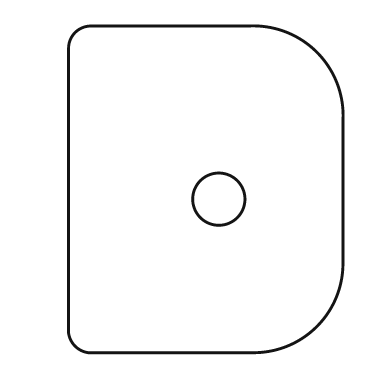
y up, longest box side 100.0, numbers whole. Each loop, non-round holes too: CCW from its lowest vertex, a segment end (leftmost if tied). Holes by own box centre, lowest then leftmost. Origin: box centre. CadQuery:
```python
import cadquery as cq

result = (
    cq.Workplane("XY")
    .moveTo(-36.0, -50.0)
    .lineTo(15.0, -50.0)
    .threePointArc((34.0, -42.0), (42.0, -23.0))
    .lineTo(42.0, 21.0)
    .threePointArc((34.0, 42.0), (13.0, 50.0))
    .lineTo(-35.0, 50.0)
    .threePointArc((-40.0, 48.0), (-42.0, 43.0))
    .lineTo(-42.0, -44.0)
    .threePointArc((-40.0, -48.0), (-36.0, -50.0))
    .close()
    .moveTo(4.0, -3.0)
    .circle(8.0)
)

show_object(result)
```